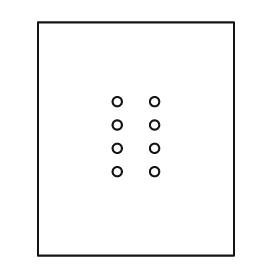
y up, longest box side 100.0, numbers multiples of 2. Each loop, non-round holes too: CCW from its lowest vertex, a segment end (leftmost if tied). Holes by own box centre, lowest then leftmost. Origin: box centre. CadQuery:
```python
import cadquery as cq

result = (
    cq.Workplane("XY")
    .moveTo(-42.0, -50.0)
    .lineTo(42.0, -50.0)
    .lineTo(42.0, 50.0)
    .lineTo(-42.0, 50.0)
    .close()
    .moveTo(-8.0, -14.0)
    .circle(2.0)
    .moveTo(8.0, -14.0)
    .circle(2.0)
    .moveTo(-8.0, -4.0)
    .circle(2.0)
    .moveTo(8.0, -4.0)
    .circle(2.0)
    .moveTo(-8.0, 6.0)
    .circle(2.0)
    .moveTo(8.0, 6.0)
    .circle(2.0)
    .moveTo(-8.0, 16.0)
    .circle(2.0)
    .moveTo(8.0, 16.0)
    .circle(2.0)
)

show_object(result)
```